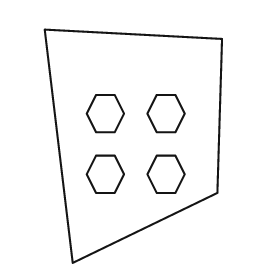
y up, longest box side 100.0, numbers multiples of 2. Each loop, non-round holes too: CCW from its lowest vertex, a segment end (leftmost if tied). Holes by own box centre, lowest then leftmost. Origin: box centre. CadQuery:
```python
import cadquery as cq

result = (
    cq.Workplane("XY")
    .moveTo(-26.0, -50.0)
    .lineTo(36.0, -20.0)
    .lineTo(38.0, 46.0)
    .lineTo(-38.0, 50.0)
    .close()
    .moveTo(-16.0, -20.0)
    .lineTo(-8.0, -20.0)
    .lineTo(-4.0, -12.0)
    .lineTo(-8.0, -4.0)
    .lineTo(-16.0, -4.0)
    .lineTo(-20.0, -12.0)
    .close()
    .moveTo(10.0, -20.0)
    .lineTo(18.0, -20.0)
    .lineTo(22.0, -12.0)
    .lineTo(18.0, -4.0)
    .lineTo(10.0, -4.0)
    .lineTo(6.0, -12.0)
    .close()
    .moveTo(-16.0, 6.0)
    .lineTo(-8.0, 6.0)
    .lineTo(-4.0, 14.0)
    .lineTo(-8.0, 22.0)
    .lineTo(-16.0, 22.0)
    .lineTo(-20.0, 14.0)
    .close()
    .moveTo(10.0, 6.0)
    .lineTo(18.0, 6.0)
    .lineTo(22.0, 14.0)
    .lineTo(18.0, 22.0)
    .lineTo(10.0, 22.0)
    .lineTo(6.0, 14.0)
    .close()
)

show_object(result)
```